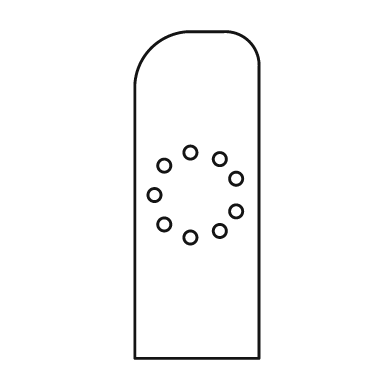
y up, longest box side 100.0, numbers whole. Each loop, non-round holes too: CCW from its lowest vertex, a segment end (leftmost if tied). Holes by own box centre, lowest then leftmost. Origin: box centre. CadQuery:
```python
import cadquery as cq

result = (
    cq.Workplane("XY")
    .moveTo(-19.0, -50.0)
    .lineTo(19.0, -50.0)
    .lineTo(19.0, 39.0)
    .threePointArc((16.0, 47.0), (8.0, 50.0))
    .lineTo(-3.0, 50.0)
    .threePointArc((-14.0, 45.0), (-19.0, 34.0))
    .close()
    .moveTo(-2.0, -13.0)
    .circle(2.0)
    .moveTo(7.0, -11.0)
    .circle(2.0)
    .moveTo(-10.0, -9.0)
    .circle(2.0)
    .moveTo(12.0, -5.0)
    .circle(2.0)
    .moveTo(-13.0, 0.0)
    .circle(2.0)
    .moveTo(12.0, 5.0)
    .circle(2.0)
    .moveTo(-10.0, 9.0)
    .circle(2.0)
    .moveTo(7.0, 11.0)
    .circle(2.0)
    .moveTo(-2.0, 13.0)
    .circle(2.0)
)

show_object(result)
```